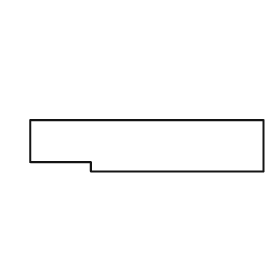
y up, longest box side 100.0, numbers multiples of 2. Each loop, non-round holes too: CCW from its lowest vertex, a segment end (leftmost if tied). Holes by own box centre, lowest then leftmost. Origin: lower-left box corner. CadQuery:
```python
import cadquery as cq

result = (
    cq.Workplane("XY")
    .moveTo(26.0, 0.0)
    .lineTo(100.0, 0.0)
    .lineTo(100.0, 22.0)
    .lineTo(0.0, 22.0)
    .lineTo(0.0, 4.0)
    .lineTo(26.0, 4.0)
    .close()
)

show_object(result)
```